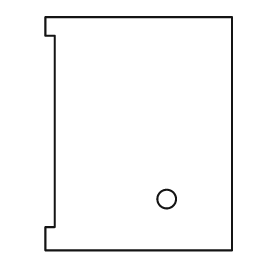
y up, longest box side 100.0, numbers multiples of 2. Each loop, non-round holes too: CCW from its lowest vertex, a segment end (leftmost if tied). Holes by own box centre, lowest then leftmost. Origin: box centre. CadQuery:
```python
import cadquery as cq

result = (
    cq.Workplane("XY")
    .moveTo(-40.0, -50.0)
    .lineTo(40.0, -50.0)
    .lineTo(40.0, 50.0)
    .lineTo(-40.0, 50.0)
    .lineTo(-40.0, 42.0)
    .lineTo(-36.0, 42.0)
    .lineTo(-36.0, -40.0)
    .lineTo(-40.0, -40.0)
    .close()
    .moveTo(12.0, -28.0)
    .circle(4.0)
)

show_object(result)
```